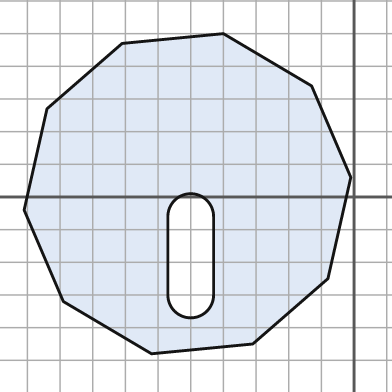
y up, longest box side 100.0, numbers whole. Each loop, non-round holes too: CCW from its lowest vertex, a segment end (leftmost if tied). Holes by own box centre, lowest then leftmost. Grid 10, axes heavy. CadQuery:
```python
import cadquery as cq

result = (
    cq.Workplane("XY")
    .moveTo(-62.0, -48.0)
    .lineTo(-31.0, -45.0)
    .lineTo(-8.0, -25.0)
    .lineTo(-1.0, 6.0)
    .lineTo(-13.0, 34.0)
    .lineTo(-40.0, 50.0)
    .lineTo(-71.0, 47.0)
    .lineTo(-94.0, 27.0)
    .lineTo(-101.0, -4.0)
    .lineTo(-89.0, -32.0)
    .close()
    .moveTo(-57.0, -30.0)
    .threePointArc((-50.0, -37.0), (-43.0, -30.0))
    .lineTo(-43.0, -6.0)
    .threePointArc((-50.0, 1.0), (-57.0, -6.0))
    .close()
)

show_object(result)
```